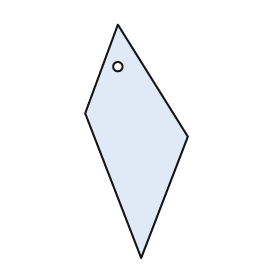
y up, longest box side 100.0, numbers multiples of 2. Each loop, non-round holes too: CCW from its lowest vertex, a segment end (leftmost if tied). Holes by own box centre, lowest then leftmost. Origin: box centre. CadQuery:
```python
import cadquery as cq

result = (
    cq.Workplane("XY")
    .moveTo(2.0, -50.0)
    .lineTo(22.0, 2.0)
    .lineTo(-8.0, 50.0)
    .lineTo(-22.0, 12.0)
    .close()
    .moveTo(-8.0, 32.0)
    .circle(2.0)
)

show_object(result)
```